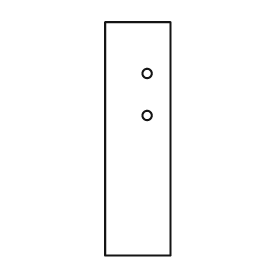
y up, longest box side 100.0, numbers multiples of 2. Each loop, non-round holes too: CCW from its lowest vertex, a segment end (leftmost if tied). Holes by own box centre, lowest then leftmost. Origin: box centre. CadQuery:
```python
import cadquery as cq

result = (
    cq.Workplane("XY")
    .moveTo(-14.0, -50.0)
    .lineTo(14.0, -50.0)
    .lineTo(14.0, 50.0)
    .lineTo(-14.0, 50.0)
    .close()
    .moveTo(4.0, 10.0)
    .circle(2.0)
    .moveTo(4.0, 28.0)
    .circle(2.0)
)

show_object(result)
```